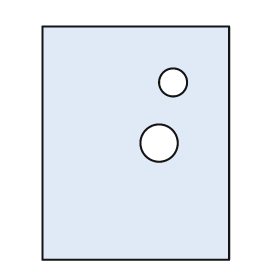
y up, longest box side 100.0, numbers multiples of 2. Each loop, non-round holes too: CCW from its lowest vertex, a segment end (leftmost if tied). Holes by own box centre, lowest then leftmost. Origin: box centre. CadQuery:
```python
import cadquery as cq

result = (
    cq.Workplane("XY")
    .moveTo(-40.0, -50.0)
    .lineTo(40.0, -50.0)
    .lineTo(40.0, 50.0)
    .lineTo(-40.0, 50.0)
    .close()
    .moveTo(10.0, 0.0)
    .circle(8.0)
    .moveTo(16.0, 26.0)
    .circle(6.0)
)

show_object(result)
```